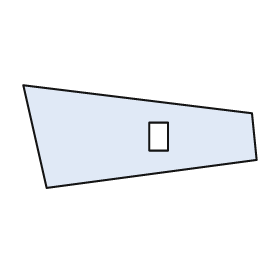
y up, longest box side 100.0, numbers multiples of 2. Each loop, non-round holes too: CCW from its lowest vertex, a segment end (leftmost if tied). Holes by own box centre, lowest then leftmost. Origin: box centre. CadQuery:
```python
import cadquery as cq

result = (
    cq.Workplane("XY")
    .moveTo(-40.0, -22.0)
    .lineTo(50.0, -10.0)
    .lineTo(48.0, 10.0)
    .lineTo(-50.0, 22.0)
    .close()
    .moveTo(4.0, -6.0)
    .lineTo(12.0, -6.0)
    .lineTo(12.0, 6.0)
    .lineTo(4.0, 6.0)
    .close()
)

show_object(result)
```